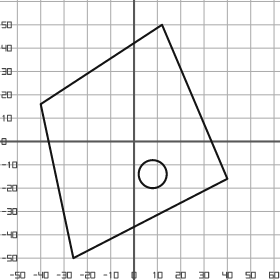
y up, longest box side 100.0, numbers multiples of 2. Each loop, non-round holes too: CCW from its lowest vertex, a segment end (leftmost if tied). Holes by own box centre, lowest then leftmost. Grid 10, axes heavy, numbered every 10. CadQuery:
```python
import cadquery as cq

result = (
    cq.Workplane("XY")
    .moveTo(-26.0, -50.0)
    .lineTo(40.0, -16.0)
    .lineTo(12.0, 50.0)
    .lineTo(-40.0, 16.0)
    .close()
    .moveTo(8.0, -14.0)
    .circle(6.0)
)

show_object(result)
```